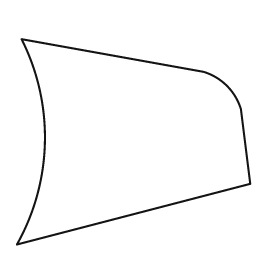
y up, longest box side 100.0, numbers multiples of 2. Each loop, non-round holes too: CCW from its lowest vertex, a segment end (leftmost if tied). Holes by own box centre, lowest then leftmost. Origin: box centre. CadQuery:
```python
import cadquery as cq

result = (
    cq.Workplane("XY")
    .moveTo(-50.0, -44.0)
    .lineTo(50.0, -18.0)
    .lineTo(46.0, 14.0)
    .threePointArc((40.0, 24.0), (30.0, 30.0))
    .lineTo(-48.0, 44.0)
    .threePointArc((-38.0, 0.0), (-50.0, -44.0))
    .close()
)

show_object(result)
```